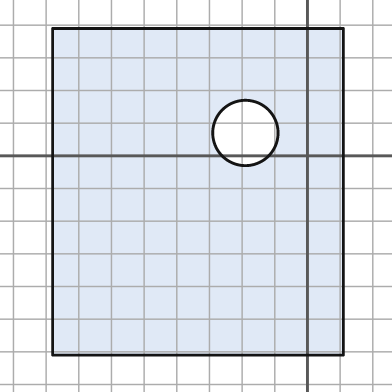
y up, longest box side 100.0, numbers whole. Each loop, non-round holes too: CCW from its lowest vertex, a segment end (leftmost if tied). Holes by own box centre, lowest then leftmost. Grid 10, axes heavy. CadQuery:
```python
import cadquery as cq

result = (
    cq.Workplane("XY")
    .moveTo(-78.0, -61.0)
    .lineTo(11.0, -61.0)
    .lineTo(11.0, 39.0)
    .lineTo(-78.0, 39.0)
    .close()
    .moveTo(-19.0, 7.0)
    .circle(10.0)
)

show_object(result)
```